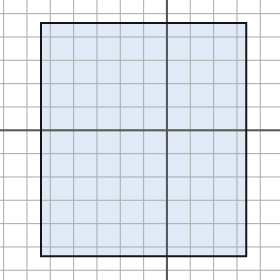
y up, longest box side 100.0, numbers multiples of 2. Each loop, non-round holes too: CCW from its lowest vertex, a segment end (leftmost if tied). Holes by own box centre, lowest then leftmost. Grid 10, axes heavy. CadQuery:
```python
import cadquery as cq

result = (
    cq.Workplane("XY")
    .moveTo(-54.0, -54.0)
    .lineTo(34.0, -54.0)
    .lineTo(34.0, 46.0)
    .lineTo(-54.0, 46.0)
    .close()
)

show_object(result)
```